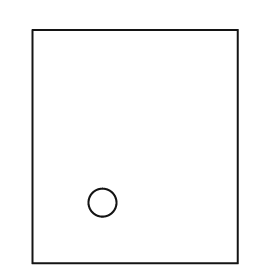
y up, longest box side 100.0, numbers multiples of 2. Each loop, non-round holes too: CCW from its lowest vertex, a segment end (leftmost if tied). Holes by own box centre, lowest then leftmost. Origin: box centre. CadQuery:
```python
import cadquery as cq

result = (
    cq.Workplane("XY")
    .moveTo(-44.0, -50.0)
    .lineTo(44.0, -50.0)
    .lineTo(44.0, 50.0)
    .lineTo(-44.0, 50.0)
    .close()
    .moveTo(-14.0, -24.0)
    .circle(6.0)
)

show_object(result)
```